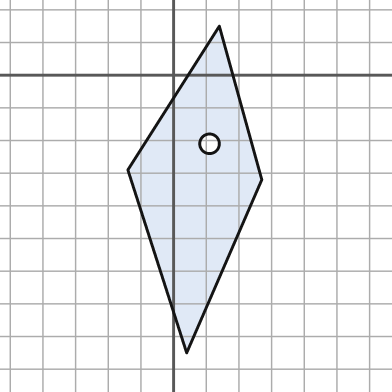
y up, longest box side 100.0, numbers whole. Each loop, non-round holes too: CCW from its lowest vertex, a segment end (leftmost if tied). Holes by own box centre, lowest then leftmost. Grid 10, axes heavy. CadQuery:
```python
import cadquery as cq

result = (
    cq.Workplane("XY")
    .moveTo(4.0, -85.0)
    .lineTo(27.0, -32.0)
    .lineTo(14.0, 15.0)
    .lineTo(-14.0, -29.0)
    .close()
    .moveTo(11.0, -21.0)
    .circle(3.0)
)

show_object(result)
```